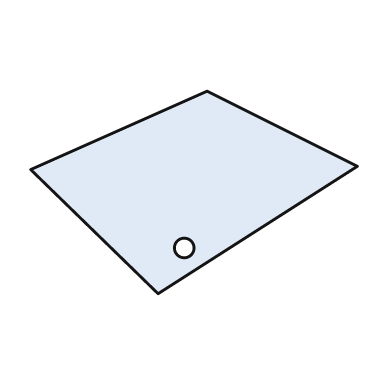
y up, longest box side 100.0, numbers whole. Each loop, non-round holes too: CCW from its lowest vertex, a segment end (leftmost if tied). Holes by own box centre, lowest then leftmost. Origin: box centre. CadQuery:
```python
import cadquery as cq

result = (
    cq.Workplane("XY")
    .moveTo(-11.0, -31.0)
    .lineTo(50.0, 8.0)
    .lineTo(4.0, 31.0)
    .lineTo(-50.0, 7.0)
    .close()
    .moveTo(-3.0, -17.0)
    .circle(3.0)
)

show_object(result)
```